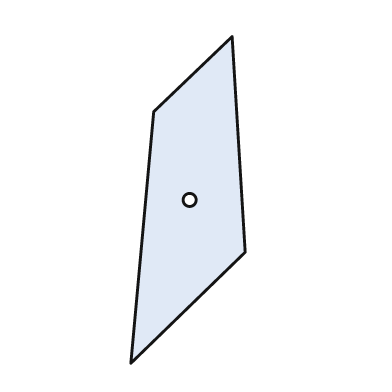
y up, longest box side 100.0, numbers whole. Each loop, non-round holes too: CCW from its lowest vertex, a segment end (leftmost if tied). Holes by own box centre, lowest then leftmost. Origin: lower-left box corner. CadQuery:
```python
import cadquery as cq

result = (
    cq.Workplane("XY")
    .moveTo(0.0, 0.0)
    .lineTo(35.0, 34.0)
    .lineTo(31.0, 100.0)
    .lineTo(7.0, 77.0)
    .close()
    .moveTo(18.0, 50.0)
    .circle(2.0)
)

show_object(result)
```